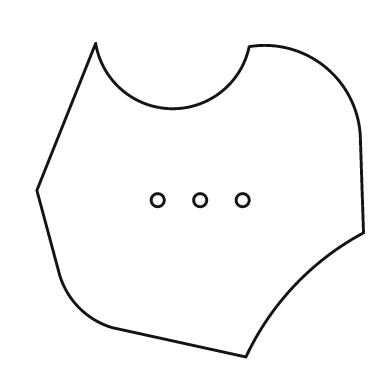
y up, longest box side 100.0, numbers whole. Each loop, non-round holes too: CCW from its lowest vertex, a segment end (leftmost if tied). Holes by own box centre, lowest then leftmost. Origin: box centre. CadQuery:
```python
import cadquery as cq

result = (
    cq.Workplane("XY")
    .moveTo(14.0, -48.0)
    .threePointArc((29.0, -26.0), (50.0, -10.0))
    .lineTo(49.0, 20.0)
    .threePointArc((38.0, 41.0), (15.0, 47.0))
    .threePointArc((-9.0, 28.0), (-32.0, 48.0))
    .lineTo(-50.0, 3.0)
    .lineTo(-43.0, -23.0)
    .threePointArc((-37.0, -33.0), (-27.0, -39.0))
    .close()
    .moveTo(-13.0, 0.0)
    .circle(2.0)
    .moveTo(0.0, 0.0)
    .circle(2.0)
    .moveTo(13.0, 0.0)
    .circle(2.0)
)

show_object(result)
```